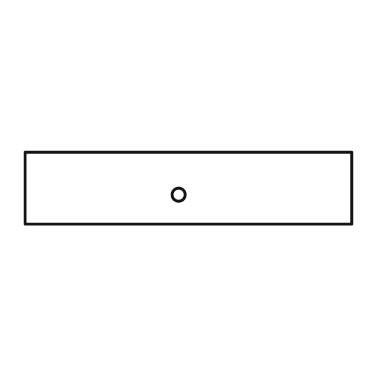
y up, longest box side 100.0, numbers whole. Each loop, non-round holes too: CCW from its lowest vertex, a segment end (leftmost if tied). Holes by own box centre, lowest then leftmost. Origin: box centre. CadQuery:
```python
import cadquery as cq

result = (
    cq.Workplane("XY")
    .moveTo(-50.0, -11.0)
    .lineTo(50.0, -11.0)
    .lineTo(50.0, 11.0)
    .lineTo(-50.0, 11.0)
    .close()
    .moveTo(-3.0, -2.0)
    .circle(2.0)
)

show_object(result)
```